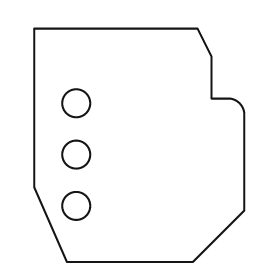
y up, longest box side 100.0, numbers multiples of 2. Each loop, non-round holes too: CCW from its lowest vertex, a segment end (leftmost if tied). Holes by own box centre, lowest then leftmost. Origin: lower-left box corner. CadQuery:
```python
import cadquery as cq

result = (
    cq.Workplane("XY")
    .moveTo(14.0, 0.0)
    .lineTo(68.0, 0.0)
    .lineTo(90.0, 22.0)
    .lineTo(90.0, 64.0)
    .threePointArc((88.0, 68.0), (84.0, 70.0))
    .lineTo(76.0, 70.0)
    .lineTo(76.0, 88.0)
    .lineTo(70.0, 100.0)
    .lineTo(0.0, 100.0)
    .lineTo(0.0, 32.0)
    .close()
    .moveTo(18.0, 24.0)
    .circle(6.0)
    .moveTo(18.0, 46.0)
    .circle(6.0)
    .moveTo(18.0, 68.0)
    .circle(6.0)
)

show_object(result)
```